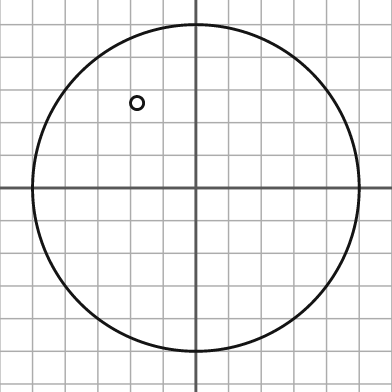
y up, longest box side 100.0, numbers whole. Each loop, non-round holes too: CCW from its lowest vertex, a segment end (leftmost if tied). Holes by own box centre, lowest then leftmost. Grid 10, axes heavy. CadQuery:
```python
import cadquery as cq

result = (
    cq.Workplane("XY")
    .moveTo(0.0, 0.0)
    .circle(50.0)
    .moveTo(-18.0, 26.0)
    .circle(2.0)
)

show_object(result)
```